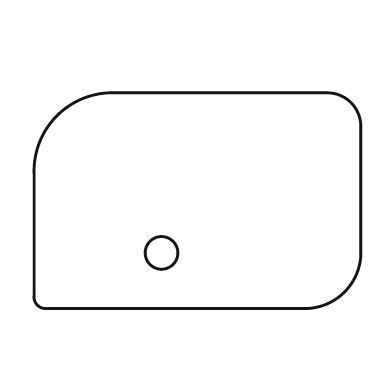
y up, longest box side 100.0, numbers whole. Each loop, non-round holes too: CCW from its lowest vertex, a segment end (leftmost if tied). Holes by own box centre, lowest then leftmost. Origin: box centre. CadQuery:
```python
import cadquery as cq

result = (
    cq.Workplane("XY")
    .moveTo(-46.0, -33.0)
    .lineTo(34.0, -33.0)
    .threePointArc((45.0, -28.0), (50.0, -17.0))
    .lineTo(50.0, 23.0)
    .threePointArc((47.0, 30.0), (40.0, 33.0))
    .lineTo(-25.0, 33.0)
    .threePointArc((-43.0, 26.0), (-50.0, 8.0))
    .lineTo(-50.0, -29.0)
    .threePointArc((-49.0, -32.0), (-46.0, -33.0))
    .close()
    .moveTo(-11.0, -16.0)
    .circle(5.0)
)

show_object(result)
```